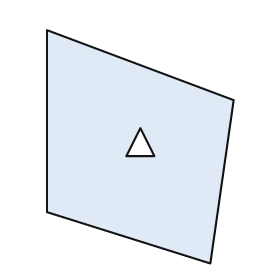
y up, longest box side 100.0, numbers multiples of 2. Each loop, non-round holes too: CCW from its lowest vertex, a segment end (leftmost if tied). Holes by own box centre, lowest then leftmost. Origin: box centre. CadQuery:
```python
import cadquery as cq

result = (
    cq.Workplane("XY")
    .moveTo(30.0, -50.0)
    .lineTo(40.0, 20.0)
    .lineTo(-40.0, 50.0)
    .lineTo(-40.0, -28.0)
    .close()
    .moveTo(-6.0, -4.0)
    .lineTo(6.0, -4.0)
    .lineTo(0.0, 8.0)
    .close()
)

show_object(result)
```